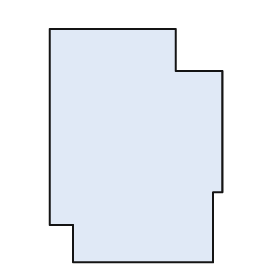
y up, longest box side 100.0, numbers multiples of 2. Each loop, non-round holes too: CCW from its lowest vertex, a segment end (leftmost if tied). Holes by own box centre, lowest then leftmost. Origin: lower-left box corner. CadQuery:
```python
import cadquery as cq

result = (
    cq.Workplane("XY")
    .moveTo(10.0, 0.0)
    .lineTo(70.0, 0.0)
    .lineTo(70.0, 30.0)
    .lineTo(74.0, 30.0)
    .lineTo(74.0, 82.0)
    .lineTo(54.0, 82.0)
    .lineTo(54.0, 100.0)
    .lineTo(0.0, 100.0)
    .lineTo(0.0, 16.0)
    .lineTo(10.0, 16.0)
    .close()
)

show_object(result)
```